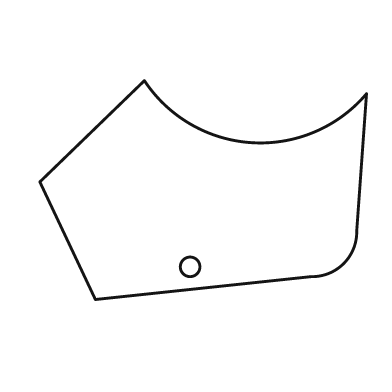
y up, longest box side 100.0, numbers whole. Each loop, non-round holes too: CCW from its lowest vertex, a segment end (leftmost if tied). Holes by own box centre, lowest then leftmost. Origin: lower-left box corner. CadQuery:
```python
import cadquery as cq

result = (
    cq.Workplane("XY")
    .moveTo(17.0, 0.0)
    .lineTo(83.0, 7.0)
    .threePointArc((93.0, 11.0), (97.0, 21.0))
    .lineTo(100.0, 63.0)
    .threePointArc((65.0, 48.0), (32.0, 67.0))
    .lineTo(0.0, 36.0)
    .close()
    .moveTo(46.0, 10.0)
    .circle(3.0)
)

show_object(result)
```